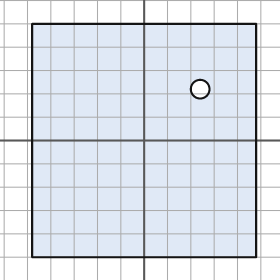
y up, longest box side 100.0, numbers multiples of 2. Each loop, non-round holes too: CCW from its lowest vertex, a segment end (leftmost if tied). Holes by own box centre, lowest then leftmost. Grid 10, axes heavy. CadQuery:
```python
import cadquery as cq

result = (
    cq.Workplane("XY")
    .moveTo(-48.0, -50.0)
    .lineTo(48.0, -50.0)
    .lineTo(48.0, 50.0)
    .lineTo(-48.0, 50.0)
    .close()
    .moveTo(24.0, 22.0)
    .circle(4.0)
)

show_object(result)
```